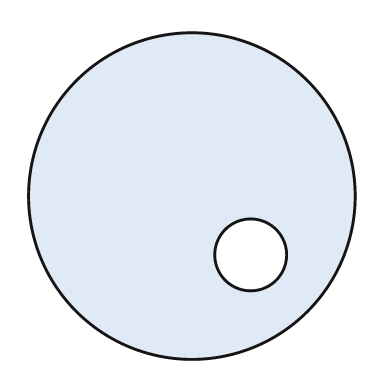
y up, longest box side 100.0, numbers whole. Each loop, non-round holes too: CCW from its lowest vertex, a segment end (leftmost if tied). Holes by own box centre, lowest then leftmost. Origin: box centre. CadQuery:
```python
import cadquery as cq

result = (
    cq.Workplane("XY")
    .moveTo(0.0, 0.0)
    .circle(50.0)
    .moveTo(18.0, -18.0)
    .circle(11.0)
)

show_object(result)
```